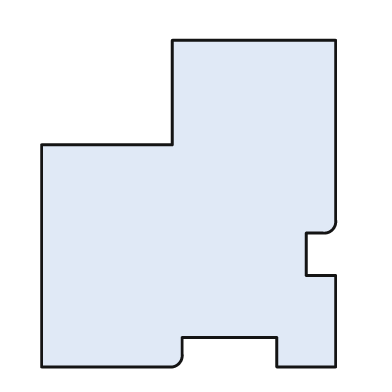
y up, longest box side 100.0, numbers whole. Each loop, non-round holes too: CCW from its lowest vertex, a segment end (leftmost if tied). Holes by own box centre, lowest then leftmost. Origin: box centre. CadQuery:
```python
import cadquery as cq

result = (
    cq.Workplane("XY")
    .moveTo(-45.0, -50.0)
    .lineTo(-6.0, -50.0)
    .threePointArc((-3.0, -49.0), (-2.0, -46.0))
    .lineTo(-2.0, -41.0)
    .lineTo(27.0, -41.0)
    .lineTo(27.0, -50.0)
    .lineTo(45.0, -50.0)
    .lineTo(45.0, -22.0)
    .lineTo(36.0, -22.0)
    .lineTo(36.0, -9.0)
    .lineTo(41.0, -9.0)
    .threePointArc((44.0, -8.0), (45.0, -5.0))
    .lineTo(45.0, 50.0)
    .lineTo(-5.0, 50.0)
    .lineTo(-5.0, 18.0)
    .lineTo(-45.0, 18.0)
    .close()
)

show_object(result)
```